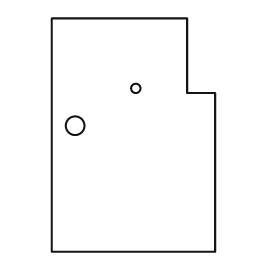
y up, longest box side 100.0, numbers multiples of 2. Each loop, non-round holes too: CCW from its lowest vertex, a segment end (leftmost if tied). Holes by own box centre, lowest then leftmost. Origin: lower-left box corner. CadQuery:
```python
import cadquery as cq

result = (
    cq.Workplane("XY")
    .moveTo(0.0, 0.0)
    .lineTo(70.0, 0.0)
    .lineTo(70.0, 68.0)
    .lineTo(58.0, 68.0)
    .lineTo(58.0, 100.0)
    .lineTo(0.0, 100.0)
    .close()
    .moveTo(10.0, 54.0)
    .circle(4.0)
    .moveTo(36.0, 70.0)
    .circle(2.0)
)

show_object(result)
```